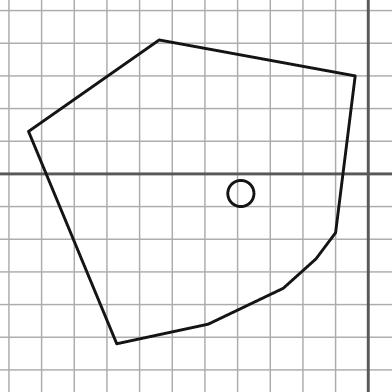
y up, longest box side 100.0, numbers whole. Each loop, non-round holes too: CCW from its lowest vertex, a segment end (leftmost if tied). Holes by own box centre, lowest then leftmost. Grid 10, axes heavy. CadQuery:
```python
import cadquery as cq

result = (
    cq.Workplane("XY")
    .moveTo(-77.0, -52.0)
    .lineTo(-49.0, -46.0)
    .lineTo(-26.0, -35.0)
    .lineTo(-16.0, -26.0)
    .lineTo(-10.0, -18.0)
    .lineTo(-4.0, 30.0)
    .lineTo(-64.0, 41.0)
    .lineTo(-104.0, 13.0)
    .close()
    .moveTo(-39.0, -6.0)
    .circle(4.0)
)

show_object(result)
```